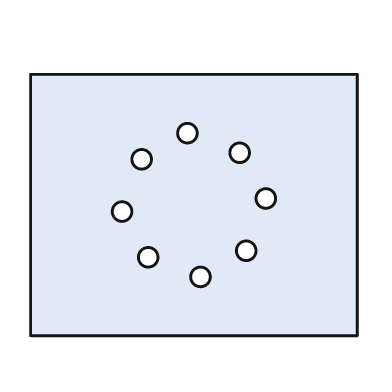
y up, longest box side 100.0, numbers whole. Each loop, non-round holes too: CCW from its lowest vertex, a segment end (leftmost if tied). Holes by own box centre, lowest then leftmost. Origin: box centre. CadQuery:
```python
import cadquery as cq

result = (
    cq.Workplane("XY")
    .moveTo(-50.0, -40.0)
    .lineTo(50.0, -40.0)
    .lineTo(50.0, 40.0)
    .lineTo(-50.0, 40.0)
    .close()
    .moveTo(2.0, -22.0)
    .circle(3.0)
    .moveTo(-14.0, -16.0)
    .circle(3.0)
    .moveTo(16.0, -14.0)
    .circle(3.0)
    .moveTo(-22.0, -2.0)
    .circle(3.0)
    .moveTo(22.0, 2.0)
    .circle(3.0)
    .moveTo(-16.0, 14.0)
    .circle(3.0)
    .moveTo(14.0, 16.0)
    .circle(3.0)
    .moveTo(-2.0, 22.0)
    .circle(3.0)
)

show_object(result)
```